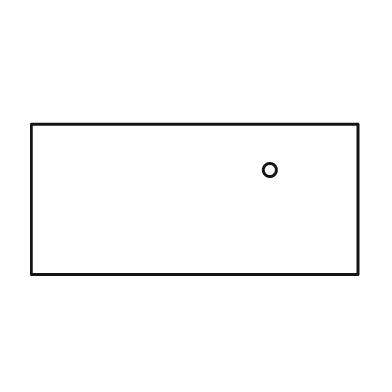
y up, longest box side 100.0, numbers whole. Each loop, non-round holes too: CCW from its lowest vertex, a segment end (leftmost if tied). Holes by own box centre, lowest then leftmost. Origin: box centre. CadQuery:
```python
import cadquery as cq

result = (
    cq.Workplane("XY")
    .moveTo(-50.0, -23.0)
    .lineTo(50.0, -23.0)
    .lineTo(50.0, 23.0)
    .lineTo(-50.0, 23.0)
    .close()
    .moveTo(23.0, 9.0)
    .circle(2.0)
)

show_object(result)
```